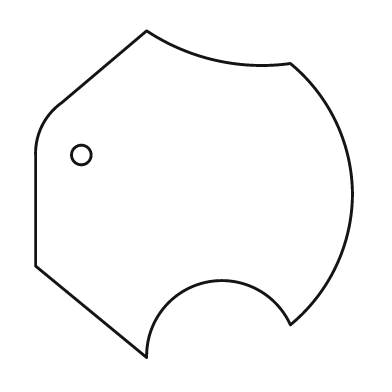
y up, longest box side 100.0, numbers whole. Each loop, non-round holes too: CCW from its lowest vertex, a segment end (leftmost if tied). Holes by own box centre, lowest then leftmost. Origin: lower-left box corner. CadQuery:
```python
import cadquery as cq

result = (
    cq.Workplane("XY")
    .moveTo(34.0, 0.0)
    .threePointArc((52.0, 23.0), (78.0, 10.0))
    .threePointArc((92.0, 28.0), (97.0, 50.0))
    .threePointArc((92.0, 72.0), (78.0, 90.0))
    .threePointArc((55.0, 91.0), (34.0, 100.0))
    .lineTo(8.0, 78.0)
    .threePointArc((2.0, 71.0), (0.0, 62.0))
    .lineTo(0.0, 28.0)
    .close()
    .moveTo(14.0, 62.0)
    .circle(3.0)
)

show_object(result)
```